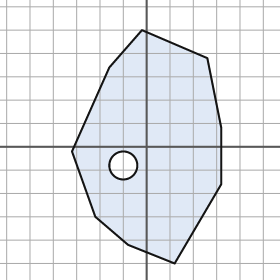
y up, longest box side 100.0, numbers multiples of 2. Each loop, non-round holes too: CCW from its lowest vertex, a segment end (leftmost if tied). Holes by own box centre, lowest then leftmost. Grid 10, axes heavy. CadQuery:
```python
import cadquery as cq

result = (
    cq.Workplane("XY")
    .moveTo(12.0, -50.0)
    .lineTo(32.0, -16.0)
    .lineTo(32.0, 8.0)
    .lineTo(26.0, 38.0)
    .lineTo(-2.0, 50.0)
    .lineTo(-16.0, 34.0)
    .lineTo(-32.0, -2.0)
    .lineTo(-22.0, -30.0)
    .lineTo(-8.0, -42.0)
    .close()
    .moveTo(-10.0, -8.0)
    .circle(6.0)
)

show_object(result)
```